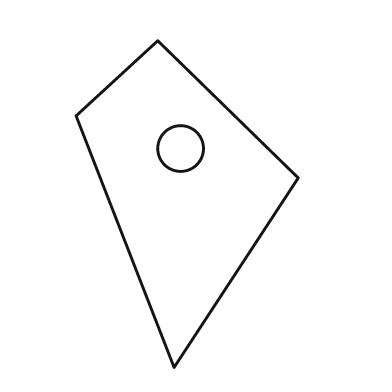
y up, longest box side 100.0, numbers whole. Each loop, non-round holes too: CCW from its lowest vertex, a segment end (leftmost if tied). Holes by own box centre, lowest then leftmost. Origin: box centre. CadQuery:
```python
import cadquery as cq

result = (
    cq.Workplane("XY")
    .moveTo(-4.0, -50.0)
    .lineTo(34.0, 8.0)
    .lineTo(-9.0, 50.0)
    .lineTo(-34.0, 27.0)
    .close()
    .moveTo(-2.0, 17.0)
    .circle(7.0)
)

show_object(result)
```